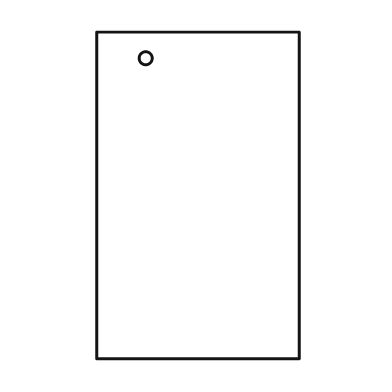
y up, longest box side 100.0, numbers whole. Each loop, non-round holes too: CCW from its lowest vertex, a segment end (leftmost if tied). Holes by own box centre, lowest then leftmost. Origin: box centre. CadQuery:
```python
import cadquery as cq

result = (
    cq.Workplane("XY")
    .moveTo(-31.0, -50.0)
    .lineTo(31.0, -50.0)
    .lineTo(31.0, 50.0)
    .lineTo(-31.0, 50.0)
    .close()
    .moveTo(-16.0, 42.0)
    .circle(2.0)
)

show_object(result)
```